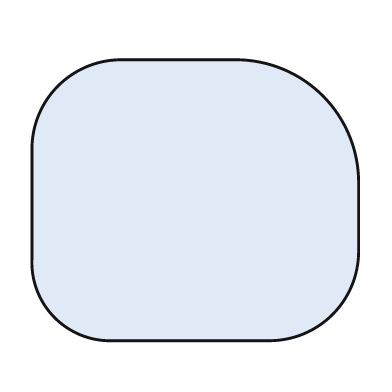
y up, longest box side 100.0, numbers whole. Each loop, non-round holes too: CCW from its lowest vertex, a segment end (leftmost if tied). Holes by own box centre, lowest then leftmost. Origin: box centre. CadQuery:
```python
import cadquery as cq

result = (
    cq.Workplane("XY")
    .moveTo(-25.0, -43.0)
    .lineTo(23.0, -43.0)
    .threePointArc((42.0, -35.0), (50.0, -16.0))
    .lineTo(50.0, 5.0)
    .threePointArc((39.0, 32.0), (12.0, 43.0))
    .lineTo(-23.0, 43.0)
    .threePointArc((-42.0, 35.0), (-50.0, 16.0))
    .lineTo(-50.0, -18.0)
    .threePointArc((-43.0, -36.0), (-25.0, -43.0))
    .close()
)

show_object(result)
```